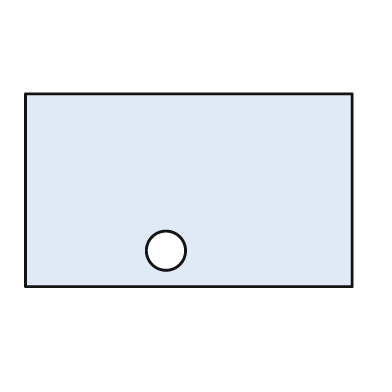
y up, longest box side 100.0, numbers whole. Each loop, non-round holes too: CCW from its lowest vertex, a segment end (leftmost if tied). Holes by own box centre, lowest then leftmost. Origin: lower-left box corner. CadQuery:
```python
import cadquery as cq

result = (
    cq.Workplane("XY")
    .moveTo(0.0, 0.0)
    .lineTo(100.0, 0.0)
    .lineTo(100.0, 59.0)
    .lineTo(0.0, 59.0)
    .close()
    .moveTo(43.0, 11.0)
    .circle(6.0)
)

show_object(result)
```